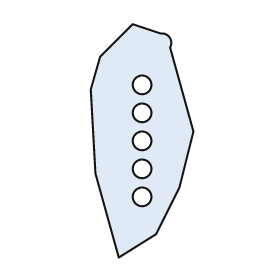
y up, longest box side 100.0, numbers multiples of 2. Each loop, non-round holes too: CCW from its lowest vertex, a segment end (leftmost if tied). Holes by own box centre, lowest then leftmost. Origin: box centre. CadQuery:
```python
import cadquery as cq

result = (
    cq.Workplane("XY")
    .moveTo(-10.0, -50.0)
    .lineTo(6.0, -40.0)
    .lineTo(16.0, -20.0)
    .lineTo(22.0, 4.0)
    .lineTo(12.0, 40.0)
    .threePointArc((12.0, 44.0), (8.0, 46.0))
    .lineTo(-4.0, 50.0)
    .lineTo(-18.0, 36.0)
    .lineTo(-22.0, 22.0)
    .lineTo(-20.0, -14.0)
    .close()
    .moveTo(0.0, -24.0)
    .circle(4.0)
    .moveTo(0.0, -12.0)
    .circle(4.0)
    .moveTo(0.0, 0.0)
    .circle(4.0)
    .moveTo(0.0, 12.0)
    .circle(4.0)
    .moveTo(0.0, 24.0)
    .circle(4.0)
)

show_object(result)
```